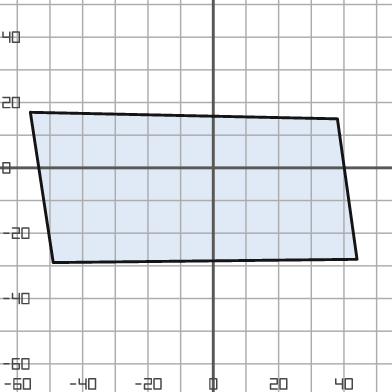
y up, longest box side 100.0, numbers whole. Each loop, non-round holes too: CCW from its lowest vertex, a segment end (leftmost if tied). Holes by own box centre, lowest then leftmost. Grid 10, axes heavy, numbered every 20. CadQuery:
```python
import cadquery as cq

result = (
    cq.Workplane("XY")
    .moveTo(-49.0, -29.0)
    .lineTo(44.0, -28.0)
    .lineTo(38.0, 15.0)
    .lineTo(-56.0, 17.0)
    .close()
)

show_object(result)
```